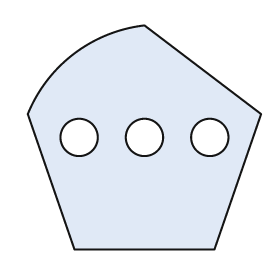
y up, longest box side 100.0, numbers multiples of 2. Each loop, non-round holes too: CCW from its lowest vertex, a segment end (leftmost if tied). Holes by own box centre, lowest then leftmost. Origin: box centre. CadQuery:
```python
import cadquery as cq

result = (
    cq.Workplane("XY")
    .moveTo(-30.0, -48.0)
    .lineTo(30.0, -48.0)
    .lineTo(50.0, 10.0)
    .lineTo(0.0, 48.0)
    .threePointArc((-30.0, 36.0), (-50.0, 10.0))
    .close()
    .moveTo(-28.0, 0.0)
    .circle(8.0)
    .moveTo(0.0, 0.0)
    .circle(8.0)
    .moveTo(28.0, 0.0)
    .circle(8.0)
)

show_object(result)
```